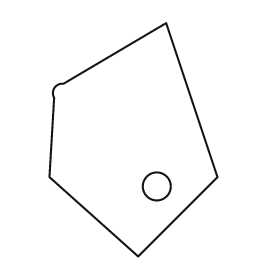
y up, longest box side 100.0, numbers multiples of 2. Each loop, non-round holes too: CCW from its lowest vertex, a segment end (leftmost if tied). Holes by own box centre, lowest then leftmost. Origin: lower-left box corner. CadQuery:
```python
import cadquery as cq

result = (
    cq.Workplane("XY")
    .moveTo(38.0, 0.0)
    .lineTo(72.0, 34.0)
    .lineTo(50.0, 100.0)
    .lineTo(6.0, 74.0)
    .threePointArc((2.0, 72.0), (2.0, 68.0))
    .lineTo(0.0, 34.0)
    .close()
    .moveTo(46.0, 30.0)
    .circle(6.0)
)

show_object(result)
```